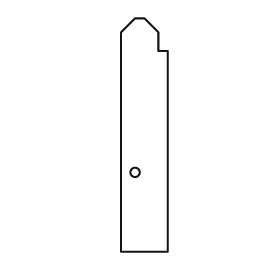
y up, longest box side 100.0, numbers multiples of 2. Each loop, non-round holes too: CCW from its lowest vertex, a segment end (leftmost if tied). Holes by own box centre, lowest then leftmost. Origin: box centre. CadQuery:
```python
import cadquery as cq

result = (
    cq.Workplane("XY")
    .moveTo(-10.0, -50.0)
    .lineTo(10.0, -50.0)
    .lineTo(10.0, 36.0)
    .lineTo(6.0, 36.0)
    .lineTo(6.0, 44.0)
    .lineTo(0.0, 50.0)
    .lineTo(-4.0, 50.0)
    .lineTo(-10.0, 44.0)
    .close()
    .moveTo(-4.0, -16.0)
    .circle(2.0)
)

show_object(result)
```